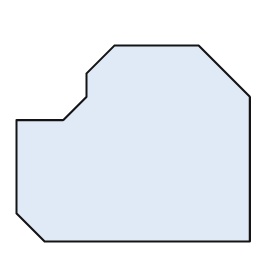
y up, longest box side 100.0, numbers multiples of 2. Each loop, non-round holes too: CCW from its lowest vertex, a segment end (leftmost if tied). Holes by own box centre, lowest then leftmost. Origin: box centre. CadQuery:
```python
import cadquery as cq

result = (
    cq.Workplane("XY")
    .moveTo(-38.0, -42.0)
    .lineTo(50.0, -42.0)
    .lineTo(50.0, 20.0)
    .lineTo(28.0, 42.0)
    .lineTo(-8.0, 42.0)
    .lineTo(-20.0, 30.0)
    .lineTo(-20.0, 20.0)
    .lineTo(-30.0, 10.0)
    .lineTo(-50.0, 10.0)
    .lineTo(-50.0, -30.0)
    .close()
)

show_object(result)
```